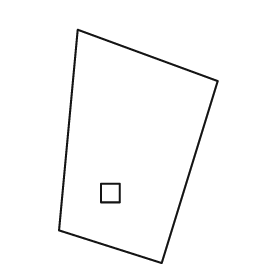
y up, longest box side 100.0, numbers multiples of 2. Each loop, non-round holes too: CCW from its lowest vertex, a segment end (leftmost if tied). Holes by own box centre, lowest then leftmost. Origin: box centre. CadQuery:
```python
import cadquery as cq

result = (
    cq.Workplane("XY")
    .moveTo(10.0, -50.0)
    .lineTo(34.0, 28.0)
    .lineTo(-26.0, 50.0)
    .lineTo(-34.0, -36.0)
    .close()
    .moveTo(-16.0, -24.0)
    .lineTo(-8.0, -24.0)
    .lineTo(-8.0, -16.0)
    .lineTo(-16.0, -16.0)
    .close()
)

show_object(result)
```